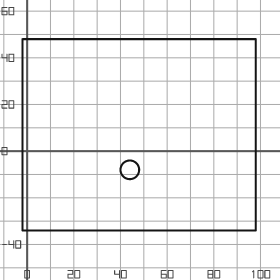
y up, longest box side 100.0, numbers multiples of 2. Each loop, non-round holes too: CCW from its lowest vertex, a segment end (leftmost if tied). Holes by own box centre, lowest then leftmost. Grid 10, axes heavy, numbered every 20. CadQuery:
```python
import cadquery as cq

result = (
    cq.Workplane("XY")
    .moveTo(-2.0, -34.0)
    .lineTo(98.0, -34.0)
    .lineTo(98.0, 48.0)
    .lineTo(-2.0, 48.0)
    .close()
    .moveTo(44.0, -8.0)
    .circle(4.0)
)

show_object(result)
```